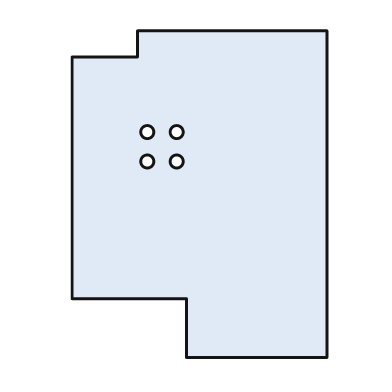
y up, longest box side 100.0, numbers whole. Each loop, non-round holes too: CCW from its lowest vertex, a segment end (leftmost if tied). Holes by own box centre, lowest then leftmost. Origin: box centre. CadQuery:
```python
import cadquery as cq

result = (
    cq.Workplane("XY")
    .moveTo(-4.0, -50.0)
    .lineTo(39.0, -50.0)
    .lineTo(39.0, 50.0)
    .lineTo(-19.0, 50.0)
    .lineTo(-19.0, 42.0)
    .lineTo(-39.0, 42.0)
    .lineTo(-39.0, -32.0)
    .lineTo(-4.0, -32.0)
    .close()
    .moveTo(-16.0, 10.0)
    .circle(2.0)
    .moveTo(-7.0, 10.0)
    .circle(2.0)
    .moveTo(-16.0, 19.0)
    .circle(2.0)
    .moveTo(-7.0, 19.0)
    .circle(2.0)
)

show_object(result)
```